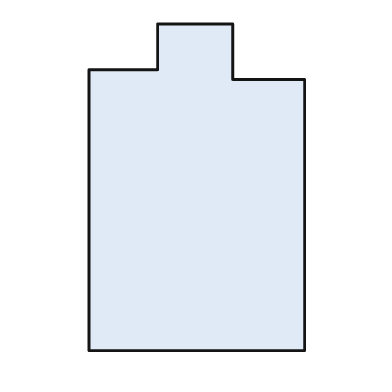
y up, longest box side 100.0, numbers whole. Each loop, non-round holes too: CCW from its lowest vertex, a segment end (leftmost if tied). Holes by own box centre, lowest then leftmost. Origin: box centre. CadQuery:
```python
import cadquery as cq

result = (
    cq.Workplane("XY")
    .moveTo(-33.0, -50.0)
    .lineTo(33.0, -50.0)
    .lineTo(33.0, 33.0)
    .lineTo(11.0, 33.0)
    .lineTo(11.0, 50.0)
    .lineTo(-12.0, 50.0)
    .lineTo(-12.0, 36.0)
    .lineTo(-33.0, 36.0)
    .close()
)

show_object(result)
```